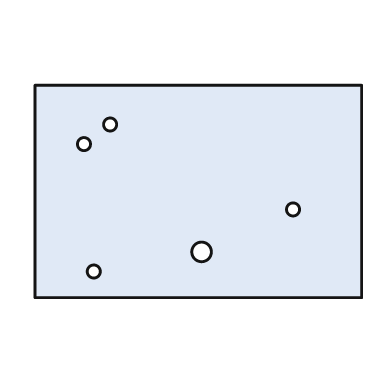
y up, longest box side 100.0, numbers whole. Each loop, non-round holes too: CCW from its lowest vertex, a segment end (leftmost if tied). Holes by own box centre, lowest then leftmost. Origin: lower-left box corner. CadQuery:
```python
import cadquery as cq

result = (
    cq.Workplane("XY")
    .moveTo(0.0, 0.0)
    .lineTo(100.0, 0.0)
    .lineTo(100.0, 65.0)
    .lineTo(0.0, 65.0)
    .close()
    .moveTo(18.0, 8.0)
    .circle(2.0)
    .moveTo(51.0, 14.0)
    .circle(3.0)
    .moveTo(79.0, 27.0)
    .circle(2.0)
    .moveTo(15.0, 47.0)
    .circle(2.0)
    .moveTo(23.0, 53.0)
    .circle(2.0)
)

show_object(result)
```